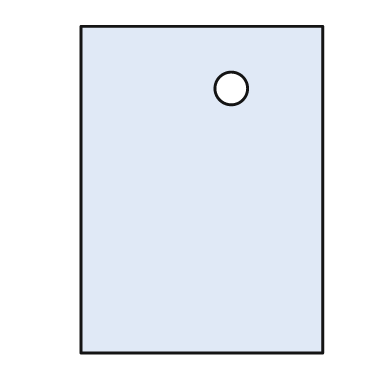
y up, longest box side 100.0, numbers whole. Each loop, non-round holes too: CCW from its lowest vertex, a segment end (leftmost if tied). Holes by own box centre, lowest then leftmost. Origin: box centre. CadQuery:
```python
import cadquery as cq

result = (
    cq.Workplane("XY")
    .moveTo(-37.0, -50.0)
    .lineTo(37.0, -50.0)
    .lineTo(37.0, 50.0)
    .lineTo(-37.0, 50.0)
    .close()
    .moveTo(9.0, 31.0)
    .circle(5.0)
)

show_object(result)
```